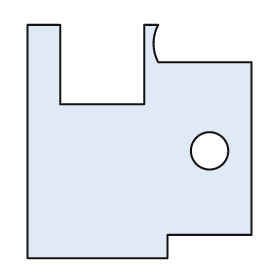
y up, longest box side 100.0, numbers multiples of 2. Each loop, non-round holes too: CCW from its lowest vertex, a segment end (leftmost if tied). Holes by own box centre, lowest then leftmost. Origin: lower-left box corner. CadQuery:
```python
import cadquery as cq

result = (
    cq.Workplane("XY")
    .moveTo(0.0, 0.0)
    .lineTo(60.0, 0.0)
    .lineTo(60.0, 10.0)
    .lineTo(96.0, 10.0)
    .lineTo(96.0, 84.0)
    .lineTo(56.0, 84.0)
    .threePointArc((54.0, 92.0), (56.0, 100.0))
    .lineTo(50.0, 100.0)
    .lineTo(50.0, 66.0)
    .lineTo(14.0, 66.0)
    .lineTo(14.0, 100.0)
    .lineTo(0.0, 100.0)
    .close()
    .moveTo(78.0, 46.0)
    .circle(8.0)
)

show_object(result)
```